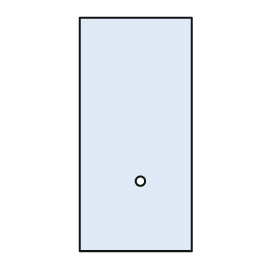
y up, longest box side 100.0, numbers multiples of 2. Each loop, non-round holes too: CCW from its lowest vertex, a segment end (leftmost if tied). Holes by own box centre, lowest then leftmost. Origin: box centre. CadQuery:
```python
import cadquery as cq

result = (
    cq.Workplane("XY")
    .moveTo(-24.0, -50.0)
    .lineTo(24.0, -50.0)
    .lineTo(24.0, 50.0)
    .lineTo(-24.0, 50.0)
    .close()
    .moveTo(2.0, -20.0)
    .circle(2.0)
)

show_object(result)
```